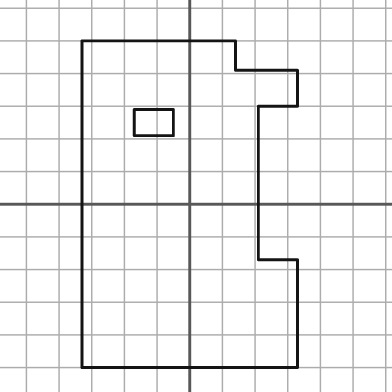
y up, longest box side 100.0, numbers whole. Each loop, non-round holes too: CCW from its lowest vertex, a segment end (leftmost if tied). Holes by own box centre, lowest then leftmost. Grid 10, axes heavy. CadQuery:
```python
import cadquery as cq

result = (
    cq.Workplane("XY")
    .moveTo(-33.0, -50.0)
    .lineTo(33.0, -50.0)
    .lineTo(33.0, -17.0)
    .lineTo(21.0, -17.0)
    .lineTo(21.0, 30.0)
    .lineTo(33.0, 30.0)
    .lineTo(33.0, 41.0)
    .lineTo(14.0, 41.0)
    .lineTo(14.0, 50.0)
    .lineTo(-33.0, 50.0)
    .close()
    .moveTo(-17.0, 21.0)
    .lineTo(-5.0, 21.0)
    .lineTo(-5.0, 29.0)
    .lineTo(-17.0, 29.0)
    .close()
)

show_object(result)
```